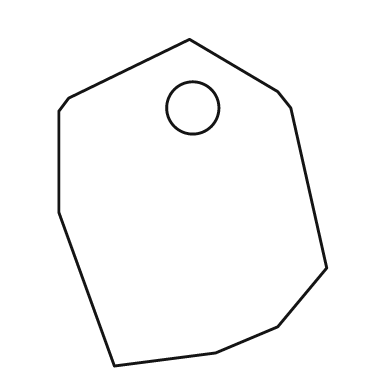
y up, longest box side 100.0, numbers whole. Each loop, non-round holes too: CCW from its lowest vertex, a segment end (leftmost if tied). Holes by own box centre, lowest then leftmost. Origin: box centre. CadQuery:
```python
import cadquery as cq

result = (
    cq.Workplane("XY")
    .moveTo(-24.0, -50.0)
    .lineTo(7.0, -46.0)
    .lineTo(26.0, -38.0)
    .lineTo(41.0, -20.0)
    .lineTo(30.0, 29.0)
    .lineTo(26.0, 34.0)
    .lineTo(-1.0, 50.0)
    .lineTo(-38.0, 32.0)
    .lineTo(-41.0, 28.0)
    .lineTo(-41.0, -3.0)
    .close()
    .moveTo(0.0, 29.0)
    .circle(8.0)
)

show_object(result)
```